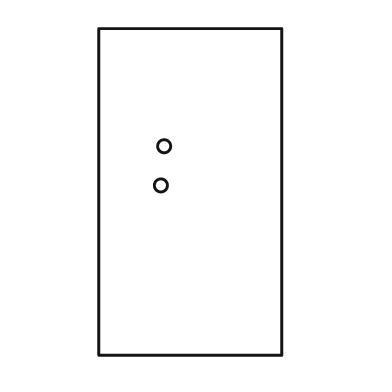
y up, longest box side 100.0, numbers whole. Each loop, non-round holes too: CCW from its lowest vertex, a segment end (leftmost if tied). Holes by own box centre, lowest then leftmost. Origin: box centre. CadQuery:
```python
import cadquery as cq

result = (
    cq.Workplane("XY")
    .moveTo(-28.0, -50.0)
    .lineTo(28.0, -50.0)
    .lineTo(28.0, 50.0)
    .lineTo(-28.0, 50.0)
    .close()
    .moveTo(-9.0, 2.0)
    .circle(2.0)
    .moveTo(-8.0, 14.0)
    .circle(2.0)
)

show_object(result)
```